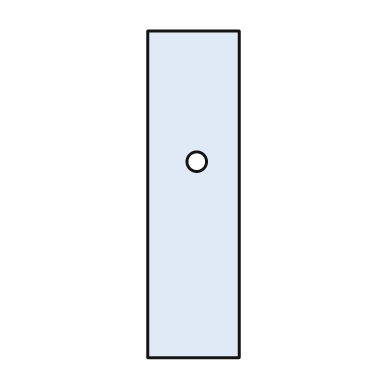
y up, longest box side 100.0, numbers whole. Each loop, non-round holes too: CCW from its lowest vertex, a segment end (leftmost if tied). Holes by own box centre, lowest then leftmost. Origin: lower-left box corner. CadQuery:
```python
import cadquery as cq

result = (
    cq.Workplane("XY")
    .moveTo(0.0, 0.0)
    .lineTo(28.0, 0.0)
    .lineTo(28.0, 100.0)
    .lineTo(0.0, 100.0)
    .close()
    .moveTo(15.0, 60.0)
    .circle(3.0)
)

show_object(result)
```